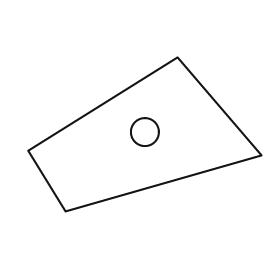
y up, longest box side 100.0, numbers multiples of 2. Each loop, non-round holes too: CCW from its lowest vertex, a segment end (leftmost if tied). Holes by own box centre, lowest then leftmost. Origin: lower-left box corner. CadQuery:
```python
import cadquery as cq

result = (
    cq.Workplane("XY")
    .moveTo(16.0, 0.0)
    .lineTo(100.0, 24.0)
    .lineTo(64.0, 66.0)
    .lineTo(0.0, 26.0)
    .close()
    .moveTo(50.0, 34.0)
    .circle(6.0)
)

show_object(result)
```